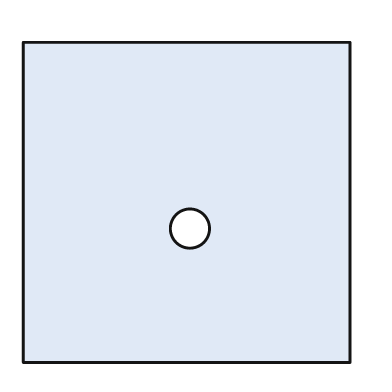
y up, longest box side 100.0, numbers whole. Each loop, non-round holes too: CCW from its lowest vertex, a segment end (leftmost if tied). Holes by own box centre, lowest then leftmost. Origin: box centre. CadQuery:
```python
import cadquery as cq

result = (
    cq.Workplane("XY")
    .moveTo(-50.0, -49.0)
    .lineTo(50.0, -49.0)
    .lineTo(50.0, 49.0)
    .lineTo(-50.0, 49.0)
    .close()
    .moveTo(1.0, -8.0)
    .circle(6.0)
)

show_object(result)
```